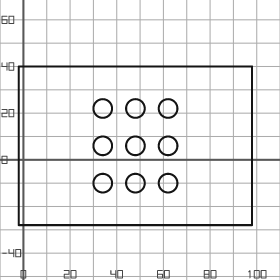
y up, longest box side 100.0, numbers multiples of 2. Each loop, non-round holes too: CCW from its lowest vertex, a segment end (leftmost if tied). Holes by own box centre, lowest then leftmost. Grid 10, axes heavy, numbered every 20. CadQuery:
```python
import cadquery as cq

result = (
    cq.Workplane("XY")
    .moveTo(-2.0, -28.0)
    .lineTo(98.0, -28.0)
    .lineTo(98.0, 40.0)
    .lineTo(-2.0, 40.0)
    .close()
    .moveTo(34.0, -10.0)
    .circle(4.0)
    .moveTo(48.0, -10.0)
    .circle(4.0)
    .moveTo(62.0, -10.0)
    .circle(4.0)
    .moveTo(34.0, 6.0)
    .circle(4.0)
    .moveTo(48.0, 6.0)
    .circle(4.0)
    .moveTo(62.0, 6.0)
    .circle(4.0)
    .moveTo(34.0, 22.0)
    .circle(4.0)
    .moveTo(48.0, 22.0)
    .circle(4.0)
    .moveTo(62.0, 22.0)
    .circle(4.0)
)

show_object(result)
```